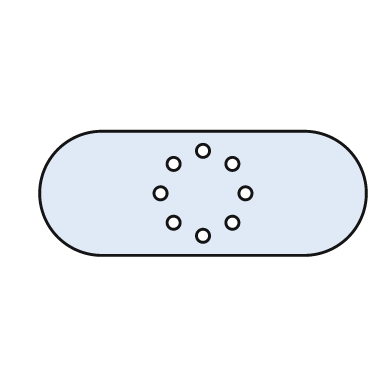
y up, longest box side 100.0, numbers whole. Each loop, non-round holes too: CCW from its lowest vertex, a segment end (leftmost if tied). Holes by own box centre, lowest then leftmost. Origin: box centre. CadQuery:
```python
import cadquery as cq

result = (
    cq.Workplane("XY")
    .moveTo(-31.0, -19.0)
    .lineTo(31.0, -19.0)
    .threePointArc((50.0, 0.0), (31.0, 19.0))
    .lineTo(-31.0, 19.0)
    .threePointArc((-50.0, 0.0), (-31.0, -19.0))
    .close()
    .moveTo(0.0, -13.0)
    .circle(2.0)
    .moveTo(-9.0, -9.0)
    .circle(2.0)
    .moveTo(9.0, -9.0)
    .circle(2.0)
    .moveTo(-13.0, 0.0)
    .circle(2.0)
    .moveTo(13.0, 0.0)
    .circle(2.0)
    .moveTo(-9.0, 9.0)
    .circle(2.0)
    .moveTo(9.0, 9.0)
    .circle(2.0)
    .moveTo(0.0, 13.0)
    .circle(2.0)
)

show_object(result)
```